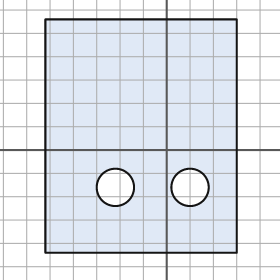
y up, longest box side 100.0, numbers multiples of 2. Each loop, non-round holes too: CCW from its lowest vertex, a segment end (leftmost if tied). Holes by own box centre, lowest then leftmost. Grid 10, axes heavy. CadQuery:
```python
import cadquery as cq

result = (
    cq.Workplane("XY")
    .moveTo(-52.0, -44.0)
    .lineTo(30.0, -44.0)
    .lineTo(30.0, 56.0)
    .lineTo(-52.0, 56.0)
    .close()
    .moveTo(-22.0, -16.0)
    .circle(8.0)
    .moveTo(10.0, -16.0)
    .circle(8.0)
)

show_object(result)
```